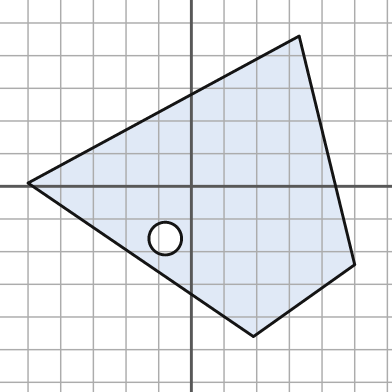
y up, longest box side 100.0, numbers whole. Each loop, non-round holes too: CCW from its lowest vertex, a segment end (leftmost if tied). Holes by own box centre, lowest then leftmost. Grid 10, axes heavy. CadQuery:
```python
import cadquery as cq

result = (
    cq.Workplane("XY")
    .moveTo(19.0, -46.0)
    .lineTo(50.0, -24.0)
    .lineTo(33.0, 46.0)
    .lineTo(-50.0, 1.0)
    .close()
    .moveTo(-8.0, -16.0)
    .circle(5.0)
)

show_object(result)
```